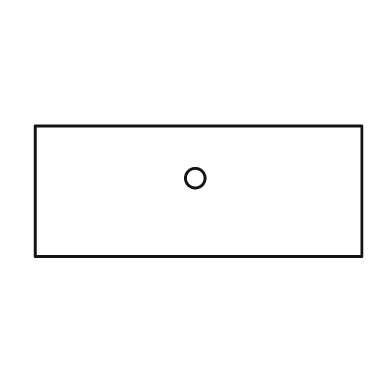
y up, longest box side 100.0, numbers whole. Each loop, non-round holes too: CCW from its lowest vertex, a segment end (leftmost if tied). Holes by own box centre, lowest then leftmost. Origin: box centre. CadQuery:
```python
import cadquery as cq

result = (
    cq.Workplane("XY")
    .moveTo(-50.0, -20.0)
    .lineTo(50.0, -20.0)
    .lineTo(50.0, 20.0)
    .lineTo(-50.0, 20.0)
    .close()
    .moveTo(-1.0, 4.0)
    .circle(3.0)
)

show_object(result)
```